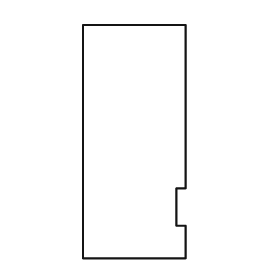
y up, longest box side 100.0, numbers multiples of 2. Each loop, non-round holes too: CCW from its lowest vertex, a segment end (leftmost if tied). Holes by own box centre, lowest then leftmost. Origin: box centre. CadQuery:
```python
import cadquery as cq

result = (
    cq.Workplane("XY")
    .moveTo(-22.0, -50.0)
    .lineTo(22.0, -50.0)
    .lineTo(22.0, -36.0)
    .lineTo(18.0, -36.0)
    .lineTo(18.0, -20.0)
    .lineTo(22.0, -20.0)
    .lineTo(22.0, 50.0)
    .lineTo(-22.0, 50.0)
    .close()
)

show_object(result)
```